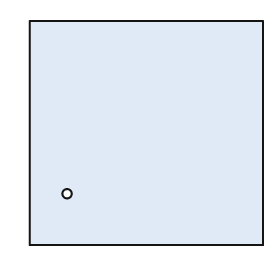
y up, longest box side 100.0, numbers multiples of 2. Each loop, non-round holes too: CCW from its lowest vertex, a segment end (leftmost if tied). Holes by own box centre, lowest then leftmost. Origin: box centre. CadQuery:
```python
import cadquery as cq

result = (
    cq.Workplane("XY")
    .moveTo(-50.0, -48.0)
    .lineTo(50.0, -48.0)
    .lineTo(50.0, 48.0)
    .lineTo(-50.0, 48.0)
    .close()
    .moveTo(-34.0, -26.0)
    .circle(2.0)
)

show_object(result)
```